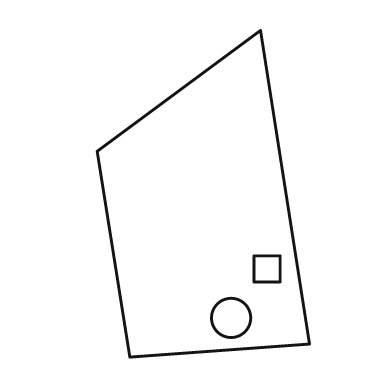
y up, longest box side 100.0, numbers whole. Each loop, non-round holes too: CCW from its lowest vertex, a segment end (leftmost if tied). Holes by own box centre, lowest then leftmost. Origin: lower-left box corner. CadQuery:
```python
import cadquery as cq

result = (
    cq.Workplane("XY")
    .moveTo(10.0, 0.0)
    .lineTo(65.0, 4.0)
    .lineTo(50.0, 100.0)
    .lineTo(0.0, 63.0)
    .close()
    .moveTo(41.0, 12.0)
    .circle(6.0)
    .moveTo(48.0, 23.0)
    .lineTo(56.0, 23.0)
    .lineTo(56.0, 31.0)
    .lineTo(48.0, 31.0)
    .close()
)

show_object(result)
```